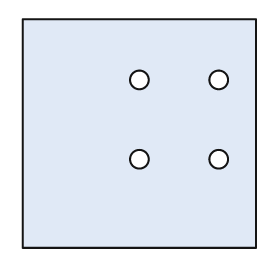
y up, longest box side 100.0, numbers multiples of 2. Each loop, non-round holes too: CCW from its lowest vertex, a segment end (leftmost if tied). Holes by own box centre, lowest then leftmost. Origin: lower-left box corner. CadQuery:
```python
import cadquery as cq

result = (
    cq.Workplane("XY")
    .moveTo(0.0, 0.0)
    .lineTo(100.0, 0.0)
    .lineTo(100.0, 98.0)
    .lineTo(0.0, 98.0)
    .close()
    .moveTo(50.0, 38.0)
    .circle(4.0)
    .moveTo(84.0, 38.0)
    .circle(4.0)
    .moveTo(50.0, 72.0)
    .circle(4.0)
    .moveTo(84.0, 72.0)
    .circle(4.0)
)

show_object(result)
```